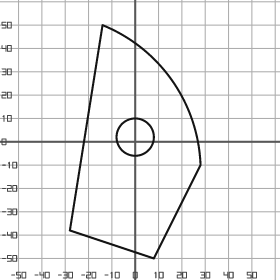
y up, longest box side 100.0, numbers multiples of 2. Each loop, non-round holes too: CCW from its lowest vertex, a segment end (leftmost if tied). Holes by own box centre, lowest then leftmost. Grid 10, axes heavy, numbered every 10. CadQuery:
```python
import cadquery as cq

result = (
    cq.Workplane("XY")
    .moveTo(8.0, -50.0)
    .lineTo(28.0, -10.0)
    .threePointArc((16.0, 26.0), (-14.0, 50.0))
    .lineTo(-28.0, -38.0)
    .close()
    .moveTo(0.0, 2.0)
    .circle(8.0)
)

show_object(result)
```